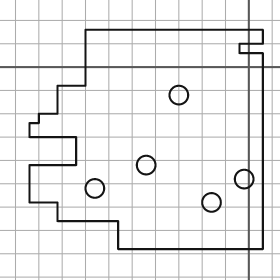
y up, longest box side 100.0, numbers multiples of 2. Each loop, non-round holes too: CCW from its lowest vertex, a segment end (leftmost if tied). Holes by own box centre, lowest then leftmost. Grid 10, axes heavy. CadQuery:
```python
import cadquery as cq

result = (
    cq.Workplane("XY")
    .moveTo(-56.0, -78.0)
    .lineTo(6.0, -78.0)
    .lineTo(6.0, 6.0)
    .lineTo(-4.0, 6.0)
    .lineTo(-4.0, 10.0)
    .lineTo(6.0, 10.0)
    .lineTo(6.0, 16.0)
    .lineTo(-70.0, 16.0)
    .lineTo(-70.0, -8.0)
    .lineTo(-82.0, -8.0)
    .lineTo(-82.0, -20.0)
    .lineTo(-90.0, -20.0)
    .lineTo(-90.0, -24.0)
    .lineTo(-94.0, -24.0)
    .lineTo(-94.0, -30.0)
    .lineTo(-74.0, -30.0)
    .lineTo(-74.0, -42.0)
    .lineTo(-94.0, -42.0)
    .lineTo(-94.0, -58.0)
    .lineTo(-82.0, -58.0)
    .lineTo(-82.0, -66.0)
    .lineTo(-56.0, -66.0)
    .close()
    .moveTo(-16.0, -58.0)
    .circle(4.0)
    .moveTo(-66.0, -52.0)
    .circle(4.0)
    .moveTo(-2.0, -48.0)
    .circle(4.0)
    .moveTo(-44.0, -42.0)
    .circle(4.0)
    .moveTo(-30.0, -12.0)
    .circle(4.0)
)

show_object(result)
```